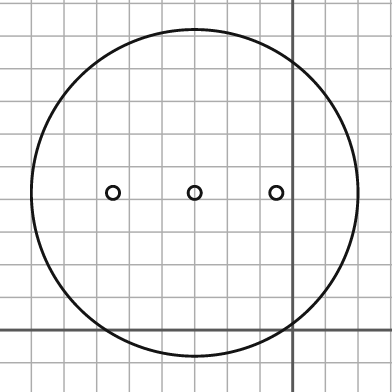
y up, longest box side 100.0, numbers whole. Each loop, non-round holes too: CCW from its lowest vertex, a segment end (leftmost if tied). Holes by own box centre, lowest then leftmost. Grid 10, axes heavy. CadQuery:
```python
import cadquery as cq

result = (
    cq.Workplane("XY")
    .moveTo(-30.0, 42.0)
    .circle(50.0)
    .moveTo(-55.0, 42.0)
    .circle(2.0)
    .moveTo(-30.0, 42.0)
    .circle(2.0)
    .moveTo(-5.0, 42.0)
    .circle(2.0)
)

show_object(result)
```